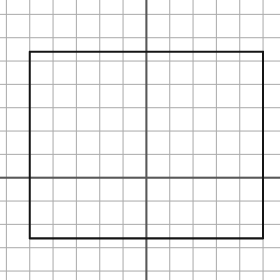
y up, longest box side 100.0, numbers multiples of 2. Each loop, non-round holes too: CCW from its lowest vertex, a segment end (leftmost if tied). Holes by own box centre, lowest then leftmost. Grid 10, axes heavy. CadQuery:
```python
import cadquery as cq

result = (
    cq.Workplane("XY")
    .moveTo(-50.0, -26.0)
    .lineTo(50.0, -26.0)
    .lineTo(50.0, 54.0)
    .lineTo(-50.0, 54.0)
    .close()
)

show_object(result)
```